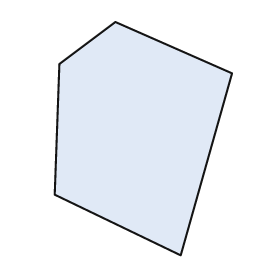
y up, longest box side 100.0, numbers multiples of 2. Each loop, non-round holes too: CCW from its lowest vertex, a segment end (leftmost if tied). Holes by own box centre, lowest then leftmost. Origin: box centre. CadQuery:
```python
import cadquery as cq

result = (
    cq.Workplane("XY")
    .moveTo(16.0, -50.0)
    .lineTo(38.0, 28.0)
    .lineTo(-12.0, 50.0)
    .lineTo(-36.0, 32.0)
    .lineTo(-38.0, -24.0)
    .close()
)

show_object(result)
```